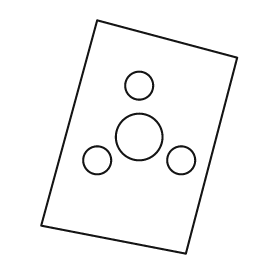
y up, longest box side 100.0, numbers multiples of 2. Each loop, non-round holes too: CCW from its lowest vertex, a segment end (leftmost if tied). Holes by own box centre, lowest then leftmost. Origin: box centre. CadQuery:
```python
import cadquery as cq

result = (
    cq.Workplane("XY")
    .moveTo(20.0, -50.0)
    .lineTo(42.0, 34.0)
    .lineTo(-18.0, 50.0)
    .lineTo(-42.0, -38.0)
    .close()
    .moveTo(-18.0, -10.0)
    .circle(6.0)
    .moveTo(18.0, -10.0)
    .circle(6.0)
    .moveTo(0.0, 0.0)
    .circle(10.0)
    .moveTo(0.0, 22.0)
    .circle(6.0)
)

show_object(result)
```